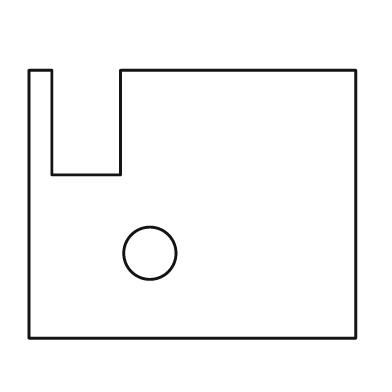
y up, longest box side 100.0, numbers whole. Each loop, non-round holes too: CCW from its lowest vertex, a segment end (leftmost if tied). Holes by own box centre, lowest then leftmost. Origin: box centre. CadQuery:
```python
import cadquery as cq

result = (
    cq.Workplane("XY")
    .moveTo(-50.0, -41.0)
    .lineTo(50.0, -41.0)
    .lineTo(50.0, 41.0)
    .lineTo(-22.0, 41.0)
    .lineTo(-22.0, 9.0)
    .lineTo(-43.0, 9.0)
    .lineTo(-43.0, 41.0)
    .lineTo(-50.0, 41.0)
    .close()
    .moveTo(-13.0, -15.0)
    .circle(8.0)
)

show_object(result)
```